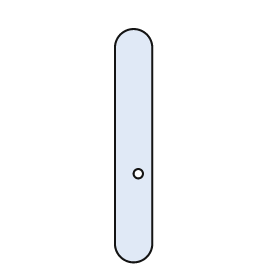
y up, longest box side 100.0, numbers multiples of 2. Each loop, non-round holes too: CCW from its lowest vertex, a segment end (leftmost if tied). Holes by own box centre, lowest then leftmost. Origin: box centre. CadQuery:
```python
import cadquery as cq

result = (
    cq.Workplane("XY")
    .moveTo(-8.0, -42.0)
    .threePointArc((0.0, -50.0), (8.0, -42.0))
    .lineTo(8.0, 42.0)
    .threePointArc((0.0, 50.0), (-8.0, 42.0))
    .close()
    .moveTo(2.0, -12.0)
    .circle(2.0)
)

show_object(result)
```